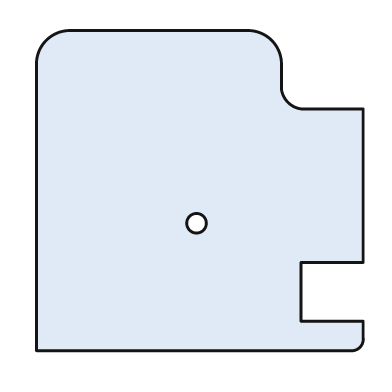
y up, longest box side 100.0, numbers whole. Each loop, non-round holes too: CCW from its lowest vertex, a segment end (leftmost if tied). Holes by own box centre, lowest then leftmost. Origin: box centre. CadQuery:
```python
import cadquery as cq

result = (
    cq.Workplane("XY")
    .moveTo(-50.0, -49.0)
    .lineTo(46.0, -49.0)
    .threePointArc((49.0, -48.0), (50.0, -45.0))
    .lineTo(50.0, -40.0)
    .lineTo(31.0, -40.0)
    .lineTo(31.0, -22.0)
    .lineTo(50.0, -22.0)
    .lineTo(50.0, 25.0)
    .lineTo(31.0, 25.0)
    .threePointArc((27.0, 27.0), (25.0, 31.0))
    .lineTo(25.0, 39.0)
    .threePointArc((22.0, 46.0), (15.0, 49.0))
    .lineTo(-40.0, 49.0)
    .threePointArc((-47.0, 46.0), (-50.0, 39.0))
    .close()
    .moveTo(-1.0, -10.0)
    .circle(3.0)
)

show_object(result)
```